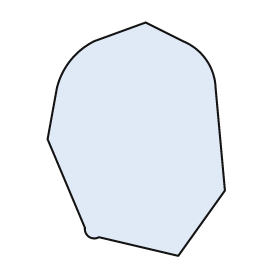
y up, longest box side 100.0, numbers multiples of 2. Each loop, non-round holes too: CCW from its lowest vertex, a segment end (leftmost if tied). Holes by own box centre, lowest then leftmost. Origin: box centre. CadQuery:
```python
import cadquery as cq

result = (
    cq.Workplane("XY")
    .moveTo(18.0, -50.0)
    .lineTo(38.0, -22.0)
    .lineTo(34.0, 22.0)
    .threePointArc((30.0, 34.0), (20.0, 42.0))
    .lineTo(4.0, 50.0)
    .lineTo(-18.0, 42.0)
    .threePointArc((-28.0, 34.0), (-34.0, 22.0))
    .lineTo(-38.0, 0.0)
    .lineTo(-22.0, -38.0)
    .threePointArc((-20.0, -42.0), (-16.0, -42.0))
    .close()
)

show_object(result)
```